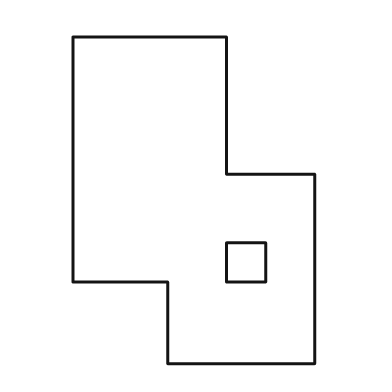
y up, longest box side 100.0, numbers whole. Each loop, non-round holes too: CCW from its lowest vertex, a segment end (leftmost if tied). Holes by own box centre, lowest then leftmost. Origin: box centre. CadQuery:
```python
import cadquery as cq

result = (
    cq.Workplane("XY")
    .moveTo(-8.0, -50.0)
    .lineTo(37.0, -50.0)
    .lineTo(37.0, 8.0)
    .lineTo(10.0, 8.0)
    .lineTo(10.0, 50.0)
    .lineTo(-37.0, 50.0)
    .lineTo(-37.0, -25.0)
    .lineTo(-8.0, -25.0)
    .close()
    .moveTo(10.0, -25.0)
    .lineTo(22.0, -25.0)
    .lineTo(22.0, -13.0)
    .lineTo(10.0, -13.0)
    .close()
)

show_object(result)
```